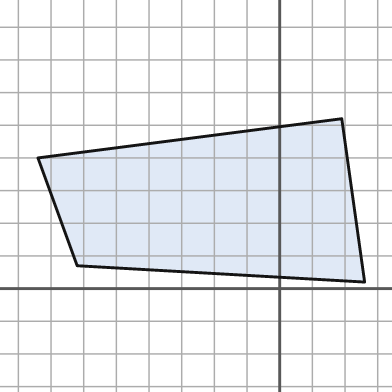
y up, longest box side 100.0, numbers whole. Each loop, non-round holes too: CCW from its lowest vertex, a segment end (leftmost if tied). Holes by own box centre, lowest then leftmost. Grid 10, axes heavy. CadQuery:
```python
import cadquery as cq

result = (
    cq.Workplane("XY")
    .moveTo(26.0, 2.0)
    .lineTo(19.0, 52.0)
    .lineTo(-74.0, 40.0)
    .lineTo(-62.0, 7.0)
    .close()
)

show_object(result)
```